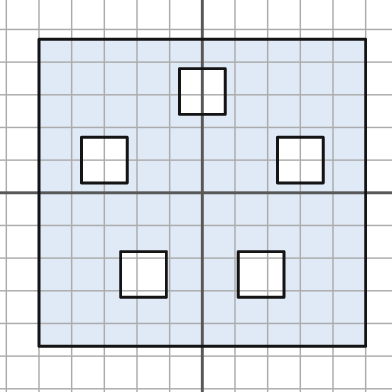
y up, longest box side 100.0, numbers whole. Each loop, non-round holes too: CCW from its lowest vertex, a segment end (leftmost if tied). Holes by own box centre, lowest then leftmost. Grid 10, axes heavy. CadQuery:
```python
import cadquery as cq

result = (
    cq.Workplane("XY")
    .moveTo(-50.0, -47.0)
    .lineTo(50.0, -47.0)
    .lineTo(50.0, 47.0)
    .lineTo(-50.0, 47.0)
    .close()
    .moveTo(-25.0, -32.0)
    .lineTo(-11.0, -32.0)
    .lineTo(-11.0, -18.0)
    .lineTo(-25.0, -18.0)
    .close()
    .moveTo(11.0, -32.0)
    .lineTo(25.0, -32.0)
    .lineTo(25.0, -18.0)
    .lineTo(11.0, -18.0)
    .close()
    .moveTo(-37.0, 3.0)
    .lineTo(-23.0, 3.0)
    .lineTo(-23.0, 17.0)
    .lineTo(-37.0, 17.0)
    .close()
    .moveTo(23.0, 3.0)
    .lineTo(37.0, 3.0)
    .lineTo(37.0, 17.0)
    .lineTo(23.0, 17.0)
    .close()
    .moveTo(-7.0, 24.0)
    .lineTo(7.0, 24.0)
    .lineTo(7.0, 38.0)
    .lineTo(-7.0, 38.0)
    .close()
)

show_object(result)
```